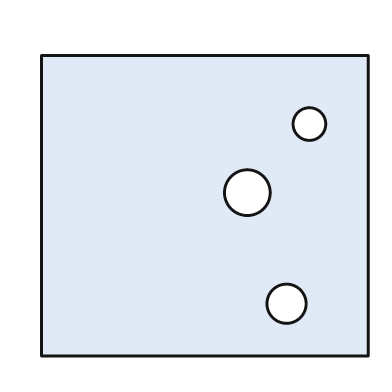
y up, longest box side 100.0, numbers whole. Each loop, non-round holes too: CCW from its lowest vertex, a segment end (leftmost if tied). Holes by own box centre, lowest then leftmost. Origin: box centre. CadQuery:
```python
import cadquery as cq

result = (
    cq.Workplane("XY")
    .moveTo(-50.0, -46.0)
    .lineTo(50.0, -46.0)
    .lineTo(50.0, 46.0)
    .lineTo(-50.0, 46.0)
    .close()
    .moveTo(25.0, -30.0)
    .circle(6.0)
    .moveTo(13.0, 4.0)
    .circle(7.0)
    .moveTo(32.0, 25.0)
    .circle(5.0)
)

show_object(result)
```